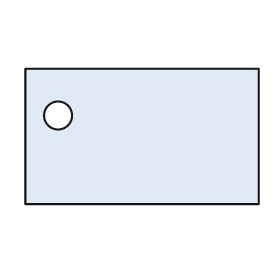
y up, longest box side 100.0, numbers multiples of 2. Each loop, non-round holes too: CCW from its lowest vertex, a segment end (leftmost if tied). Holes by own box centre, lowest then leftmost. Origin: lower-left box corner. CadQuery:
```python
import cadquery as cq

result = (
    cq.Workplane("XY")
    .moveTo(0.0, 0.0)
    .lineTo(100.0, 0.0)
    .lineTo(100.0, 58.0)
    .lineTo(0.0, 58.0)
    .close()
    .moveTo(14.0, 38.0)
    .circle(6.0)
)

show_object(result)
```